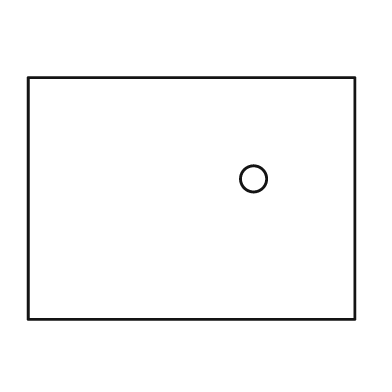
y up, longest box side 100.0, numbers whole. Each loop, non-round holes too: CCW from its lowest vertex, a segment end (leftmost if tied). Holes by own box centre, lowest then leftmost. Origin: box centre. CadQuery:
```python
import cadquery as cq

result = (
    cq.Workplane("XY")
    .moveTo(-50.0, -37.0)
    .lineTo(50.0, -37.0)
    .lineTo(50.0, 37.0)
    .lineTo(-50.0, 37.0)
    .close()
    .moveTo(19.0, 6.0)
    .circle(4.0)
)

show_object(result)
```